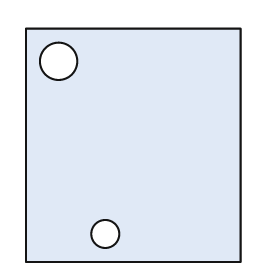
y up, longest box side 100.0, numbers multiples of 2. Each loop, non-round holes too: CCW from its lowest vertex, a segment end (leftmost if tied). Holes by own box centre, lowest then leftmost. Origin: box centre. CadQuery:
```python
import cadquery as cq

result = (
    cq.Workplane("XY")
    .moveTo(-46.0, -50.0)
    .lineTo(46.0, -50.0)
    .lineTo(46.0, 50.0)
    .lineTo(-46.0, 50.0)
    .close()
    .moveTo(-12.0, -38.0)
    .circle(6.0)
    .moveTo(-32.0, 36.0)
    .circle(8.0)
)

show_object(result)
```